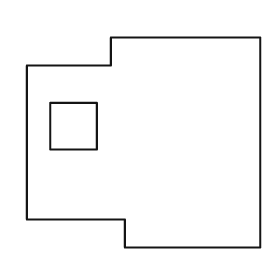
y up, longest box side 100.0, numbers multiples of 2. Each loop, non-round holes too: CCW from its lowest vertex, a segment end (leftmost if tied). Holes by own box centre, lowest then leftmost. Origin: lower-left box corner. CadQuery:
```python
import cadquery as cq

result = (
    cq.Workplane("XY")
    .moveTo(42.0, 0.0)
    .lineTo(100.0, 0.0)
    .lineTo(100.0, 90.0)
    .lineTo(36.0, 90.0)
    .lineTo(36.0, 78.0)
    .lineTo(0.0, 78.0)
    .lineTo(0.0, 12.0)
    .lineTo(42.0, 12.0)
    .close()
    .moveTo(10.0, 42.0)
    .lineTo(30.0, 42.0)
    .lineTo(30.0, 62.0)
    .lineTo(10.0, 62.0)
    .close()
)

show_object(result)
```